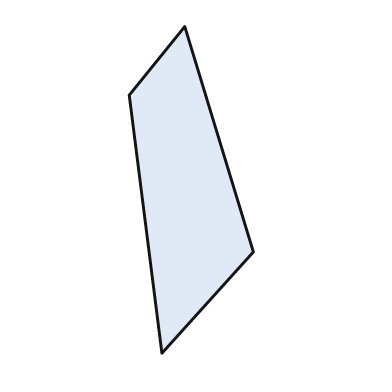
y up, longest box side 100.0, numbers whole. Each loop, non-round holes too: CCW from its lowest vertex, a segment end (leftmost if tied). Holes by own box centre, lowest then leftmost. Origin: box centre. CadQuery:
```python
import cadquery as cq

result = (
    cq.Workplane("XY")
    .moveTo(-9.0, -50.0)
    .lineTo(19.0, -19.0)
    .lineTo(-2.0, 50.0)
    .lineTo(-19.0, 29.0)
    .close()
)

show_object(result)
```